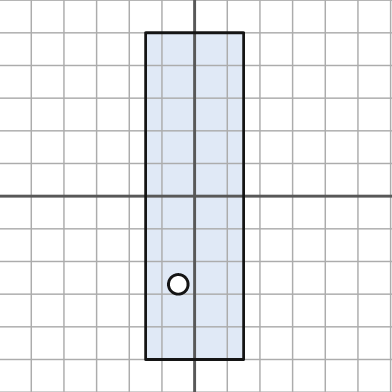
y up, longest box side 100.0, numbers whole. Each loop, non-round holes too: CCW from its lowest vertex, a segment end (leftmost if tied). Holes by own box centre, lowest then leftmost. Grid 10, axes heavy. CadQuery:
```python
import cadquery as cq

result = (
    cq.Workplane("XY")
    .moveTo(-15.0, -50.0)
    .lineTo(15.0, -50.0)
    .lineTo(15.0, 50.0)
    .lineTo(-15.0, 50.0)
    .close()
    .moveTo(-5.0, -27.0)
    .circle(3.0)
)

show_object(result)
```